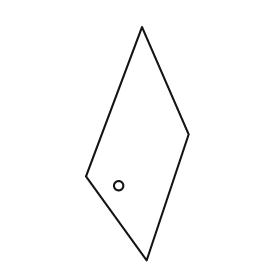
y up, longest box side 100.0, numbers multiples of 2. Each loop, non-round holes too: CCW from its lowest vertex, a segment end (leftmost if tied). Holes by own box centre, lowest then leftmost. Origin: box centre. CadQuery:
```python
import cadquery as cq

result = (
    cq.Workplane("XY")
    .moveTo(4.0, -50.0)
    .lineTo(22.0, 4.0)
    .lineTo(2.0, 50.0)
    .lineTo(-22.0, -14.0)
    .close()
    .moveTo(-8.0, -18.0)
    .circle(2.0)
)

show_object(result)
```